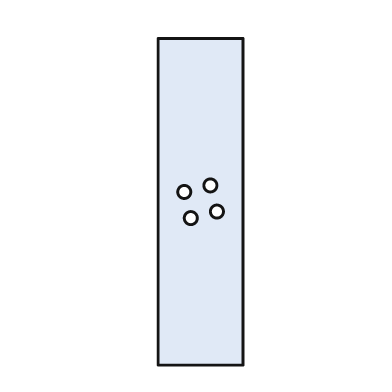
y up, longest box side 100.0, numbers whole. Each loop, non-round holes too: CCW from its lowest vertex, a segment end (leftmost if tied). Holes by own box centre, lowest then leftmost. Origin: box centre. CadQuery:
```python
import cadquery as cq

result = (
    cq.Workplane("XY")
    .moveTo(-13.0, -50.0)
    .lineTo(13.0, -50.0)
    .lineTo(13.0, 50.0)
    .lineTo(-13.0, 50.0)
    .close()
    .moveTo(-3.0, -5.0)
    .circle(2.0)
    .moveTo(5.0, -3.0)
    .circle(2.0)
    .moveTo(-5.0, 3.0)
    .circle(2.0)
    .moveTo(3.0, 5.0)
    .circle(2.0)
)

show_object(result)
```